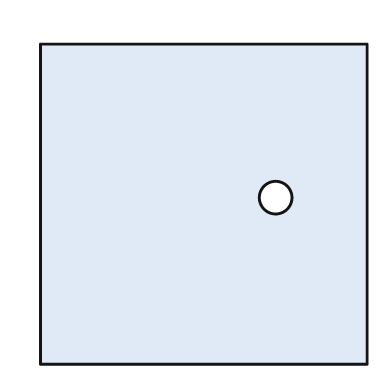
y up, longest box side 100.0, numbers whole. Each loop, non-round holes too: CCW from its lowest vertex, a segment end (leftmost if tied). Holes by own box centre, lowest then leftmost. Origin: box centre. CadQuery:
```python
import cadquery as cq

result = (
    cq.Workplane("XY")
    .moveTo(-50.0, -49.0)
    .lineTo(50.0, -49.0)
    .lineTo(50.0, 49.0)
    .lineTo(-50.0, 49.0)
    .close()
    .moveTo(22.0, 2.0)
    .circle(5.0)
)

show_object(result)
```